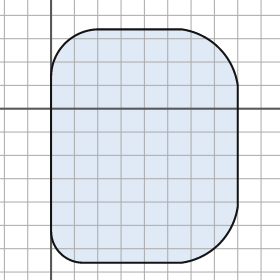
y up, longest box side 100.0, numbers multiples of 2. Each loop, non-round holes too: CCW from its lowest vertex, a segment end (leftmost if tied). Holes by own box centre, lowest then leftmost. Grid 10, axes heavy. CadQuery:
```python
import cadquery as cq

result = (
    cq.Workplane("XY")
    .moveTo(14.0, -66.0)
    .lineTo(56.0, -66.0)
    .threePointArc((72.0, -58.0), (80.0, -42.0))
    .lineTo(80.0, 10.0)
    .threePointArc((72.0, 26.0), (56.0, 34.0))
    .lineTo(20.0, 34.0)
    .threePointArc((6.0, 28.0), (0.0, 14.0))
    .lineTo(0.0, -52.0)
    .threePointArc((4.0, -62.0), (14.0, -66.0))
    .close()
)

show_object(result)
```